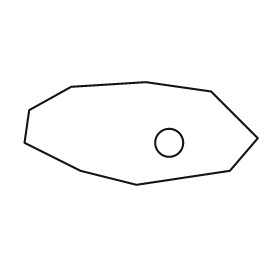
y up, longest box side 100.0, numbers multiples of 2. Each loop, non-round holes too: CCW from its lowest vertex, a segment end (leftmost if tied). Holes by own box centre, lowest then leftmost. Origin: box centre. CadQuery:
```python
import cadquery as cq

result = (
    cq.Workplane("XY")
    .moveTo(-2.0, -22.0)
    .lineTo(38.0, -16.0)
    .lineTo(50.0, -2.0)
    .lineTo(30.0, 18.0)
    .lineTo(2.0, 22.0)
    .lineTo(-30.0, 20.0)
    .lineTo(-48.0, 10.0)
    .lineTo(-50.0, -4.0)
    .lineTo(-26.0, -16.0)
    .close()
    .moveTo(12.0, -4.0)
    .circle(6.0)
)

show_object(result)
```